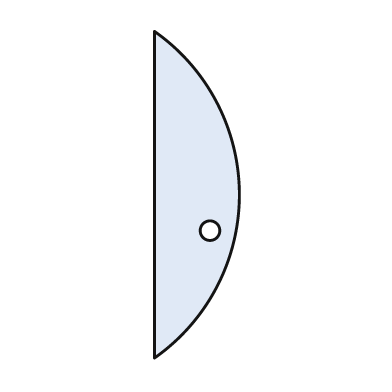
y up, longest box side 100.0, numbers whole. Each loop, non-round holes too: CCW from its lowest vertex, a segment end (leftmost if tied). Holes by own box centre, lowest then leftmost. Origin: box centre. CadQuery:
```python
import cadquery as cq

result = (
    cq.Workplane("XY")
    .moveTo(-13.0, -50.0)
    .threePointArc((13.0, 0.0), (-13.0, 50.0))
    .close()
    .moveTo(4.0, -11.0)
    .circle(3.0)
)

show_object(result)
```